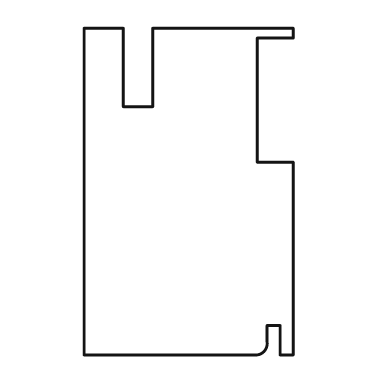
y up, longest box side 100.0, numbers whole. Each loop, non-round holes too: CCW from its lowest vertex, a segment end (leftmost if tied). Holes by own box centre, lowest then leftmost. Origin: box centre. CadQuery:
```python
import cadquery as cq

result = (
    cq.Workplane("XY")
    .moveTo(-32.0, -50.0)
    .lineTo(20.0, -50.0)
    .threePointArc((23.0, -49.0), (24.0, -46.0))
    .lineTo(24.0, -41.0)
    .lineTo(28.0, -41.0)
    .lineTo(28.0, -50.0)
    .lineTo(32.0, -50.0)
    .lineTo(32.0, 9.0)
    .lineTo(21.0, 9.0)
    .lineTo(21.0, 47.0)
    .lineTo(32.0, 47.0)
    .lineTo(32.0, 50.0)
    .lineTo(-11.0, 50.0)
    .lineTo(-11.0, 26.0)
    .lineTo(-20.0, 26.0)
    .lineTo(-20.0, 50.0)
    .lineTo(-32.0, 50.0)
    .close()
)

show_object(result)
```